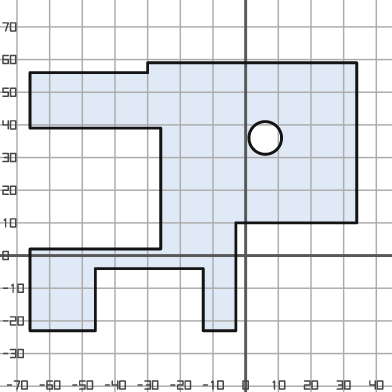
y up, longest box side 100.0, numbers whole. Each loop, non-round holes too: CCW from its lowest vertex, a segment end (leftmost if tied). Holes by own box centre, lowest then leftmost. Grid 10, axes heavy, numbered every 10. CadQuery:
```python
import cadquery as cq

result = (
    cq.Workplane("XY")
    .moveTo(-66.0, -23.0)
    .lineTo(-46.0, -23.0)
    .lineTo(-46.0, -4.0)
    .lineTo(-13.0, -4.0)
    .lineTo(-13.0, -23.0)
    .lineTo(-3.0, -23.0)
    .lineTo(-3.0, 10.0)
    .lineTo(34.0, 10.0)
    .lineTo(34.0, 59.0)
    .lineTo(-30.0, 59.0)
    .lineTo(-30.0, 56.0)
    .lineTo(-66.0, 56.0)
    .lineTo(-66.0, 39.0)
    .lineTo(-26.0, 39.0)
    .lineTo(-26.0, 2.0)
    .lineTo(-66.0, 2.0)
    .close()
    .moveTo(6.0, 36.0)
    .circle(5.0)
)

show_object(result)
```